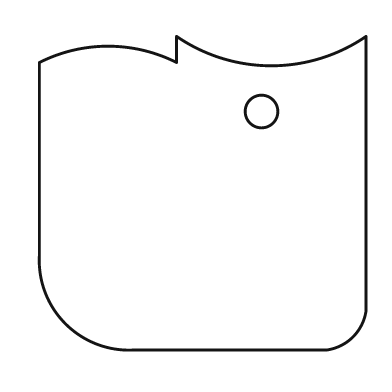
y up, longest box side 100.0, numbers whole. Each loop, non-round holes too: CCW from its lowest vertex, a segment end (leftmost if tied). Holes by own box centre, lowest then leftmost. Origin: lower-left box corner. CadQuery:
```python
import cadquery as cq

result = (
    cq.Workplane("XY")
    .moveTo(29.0, 0.0)
    .lineTo(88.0, 0.0)
    .threePointArc((96.0, 4.0), (100.0, 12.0))
    .lineTo(100.0, 96.0)
    .threePointArc((71.0, 87.0), (42.0, 96.0))
    .lineTo(42.0, 88.0)
    .threePointArc((21.0, 93.0), (0.0, 88.0))
    .lineTo(0.0, 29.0)
    .threePointArc((8.0, 8.0), (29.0, 0.0))
    .close()
    .moveTo(68.0, 73.0)
    .circle(5.0)
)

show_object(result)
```